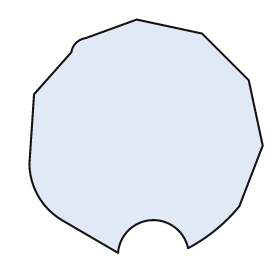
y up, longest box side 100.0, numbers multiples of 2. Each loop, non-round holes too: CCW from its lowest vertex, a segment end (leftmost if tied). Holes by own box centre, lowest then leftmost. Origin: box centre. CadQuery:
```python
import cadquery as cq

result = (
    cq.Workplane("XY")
    .moveTo(-12.0, -50.0)
    .threePointArc((2.0, -36.0), (18.0, -48.0))
    .threePointArc((30.0, -40.0), (40.0, -30.0))
    .lineTo(50.0, -4.0)
    .lineTo(44.0, 24.0)
    .lineTo(24.0, 44.0)
    .lineTo(-4.0, 50.0)
    .lineTo(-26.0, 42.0)
    .threePointArc((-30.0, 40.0), (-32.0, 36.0))
    .lineTo(-48.0, 18.0)
    .lineTo(-50.0, -12.0)
    .threePointArc((-46.0, -26.0), (-36.0, -36.0))
    .close()
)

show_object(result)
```